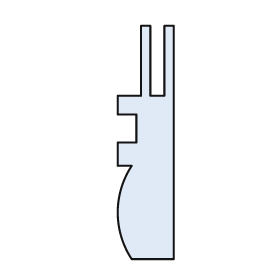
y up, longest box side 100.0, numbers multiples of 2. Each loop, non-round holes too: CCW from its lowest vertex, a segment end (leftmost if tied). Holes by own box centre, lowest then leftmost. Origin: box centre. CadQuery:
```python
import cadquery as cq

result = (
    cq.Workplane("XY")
    .moveTo(-6.0, -50.0)
    .lineTo(12.0, -50.0)
    .lineTo(12.0, 50.0)
    .lineTo(8.0, 50.0)
    .lineTo(8.0, 20.0)
    .lineTo(2.0, 20.0)
    .lineTo(2.0, 50.0)
    .lineTo(-2.0, 50.0)
    .lineTo(-2.0, 20.0)
    .lineTo(-12.0, 20.0)
    .lineTo(-12.0, 12.0)
    .lineTo(-4.0, 12.0)
    .lineTo(-4.0, 0.0)
    .lineTo(-12.0, 0.0)
    .lineTo(-12.0, -10.0)
    .lineTo(-6.0, -10.0)
    .threePointArc((-12.0, -30.0), (-6.0, -50.0))
    .close()
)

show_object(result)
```